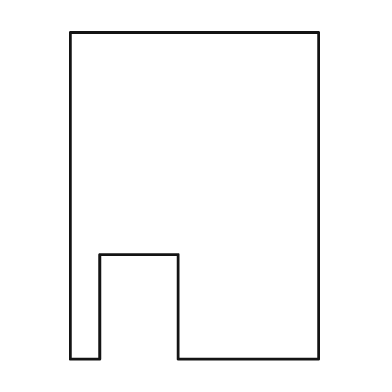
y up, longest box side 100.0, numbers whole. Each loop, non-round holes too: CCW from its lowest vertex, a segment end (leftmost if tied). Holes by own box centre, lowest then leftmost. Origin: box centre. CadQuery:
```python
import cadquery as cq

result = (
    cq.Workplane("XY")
    .moveTo(-38.0, -50.0)
    .lineTo(-29.0, -50.0)
    .lineTo(-29.0, -18.0)
    .lineTo(-5.0, -18.0)
    .lineTo(-5.0, -50.0)
    .lineTo(38.0, -50.0)
    .lineTo(38.0, 50.0)
    .lineTo(-38.0, 50.0)
    .close()
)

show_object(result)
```